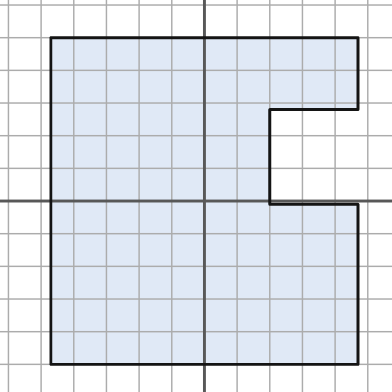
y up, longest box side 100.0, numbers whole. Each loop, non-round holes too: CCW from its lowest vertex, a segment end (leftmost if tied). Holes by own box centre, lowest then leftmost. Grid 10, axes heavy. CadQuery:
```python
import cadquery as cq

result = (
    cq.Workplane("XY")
    .moveTo(-47.0, -50.0)
    .lineTo(47.0, -50.0)
    .lineTo(47.0, -1.0)
    .lineTo(20.0, -1.0)
    .lineTo(20.0, 28.0)
    .lineTo(47.0, 28.0)
    .lineTo(47.0, 50.0)
    .lineTo(-47.0, 50.0)
    .close()
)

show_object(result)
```